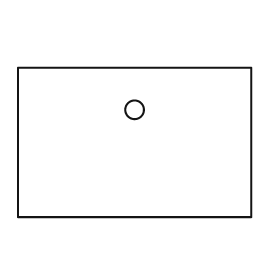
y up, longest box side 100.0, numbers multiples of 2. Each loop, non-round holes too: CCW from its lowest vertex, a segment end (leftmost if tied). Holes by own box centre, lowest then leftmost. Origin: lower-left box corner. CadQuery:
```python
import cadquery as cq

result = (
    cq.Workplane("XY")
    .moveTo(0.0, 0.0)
    .lineTo(100.0, 0.0)
    .lineTo(100.0, 64.0)
    .lineTo(0.0, 64.0)
    .close()
    .moveTo(50.0, 46.0)
    .circle(4.0)
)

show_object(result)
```